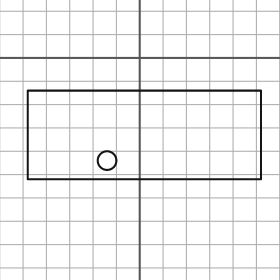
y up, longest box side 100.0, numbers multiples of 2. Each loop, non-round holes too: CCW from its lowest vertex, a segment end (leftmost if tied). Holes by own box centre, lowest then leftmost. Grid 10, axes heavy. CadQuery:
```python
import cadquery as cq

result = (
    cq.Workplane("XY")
    .moveTo(-48.0, -52.0)
    .lineTo(52.0, -52.0)
    .lineTo(52.0, -14.0)
    .lineTo(-48.0, -14.0)
    .close()
    .moveTo(-14.0, -44.0)
    .circle(4.0)
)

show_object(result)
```